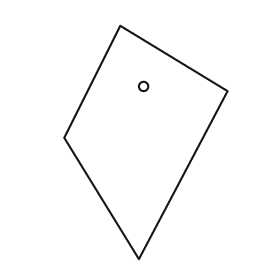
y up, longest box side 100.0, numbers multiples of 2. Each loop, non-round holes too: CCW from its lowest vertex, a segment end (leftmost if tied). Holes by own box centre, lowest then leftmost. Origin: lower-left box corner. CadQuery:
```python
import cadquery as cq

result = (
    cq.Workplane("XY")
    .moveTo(32.0, 0.0)
    .lineTo(70.0, 72.0)
    .lineTo(24.0, 100.0)
    .lineTo(0.0, 52.0)
    .close()
    .moveTo(34.0, 74.0)
    .circle(2.0)
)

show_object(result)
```